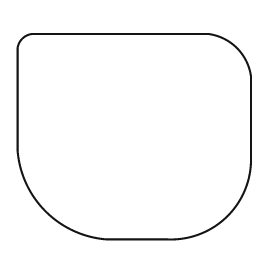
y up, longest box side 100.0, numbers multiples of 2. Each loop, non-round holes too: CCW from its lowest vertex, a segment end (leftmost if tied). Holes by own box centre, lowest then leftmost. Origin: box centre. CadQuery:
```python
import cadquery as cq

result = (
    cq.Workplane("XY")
    .moveTo(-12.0, -44.0)
    .lineTo(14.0, -44.0)
    .threePointArc((40.0, -34.0), (50.0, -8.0))
    .lineTo(50.0, 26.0)
    .threePointArc((44.0, 38.0), (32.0, 44.0))
    .lineTo(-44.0, 44.0)
    .threePointArc((-48.0, 42.0), (-50.0, 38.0))
    .lineTo(-50.0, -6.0)
    .threePointArc((-38.0, -32.0), (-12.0, -44.0))
    .close()
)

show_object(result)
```